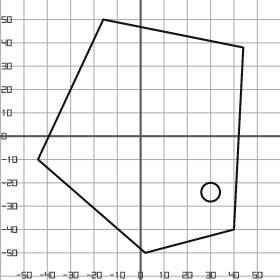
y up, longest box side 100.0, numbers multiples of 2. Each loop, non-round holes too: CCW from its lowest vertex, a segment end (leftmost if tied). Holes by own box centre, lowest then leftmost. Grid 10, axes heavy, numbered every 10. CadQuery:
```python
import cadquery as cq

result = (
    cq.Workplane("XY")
    .moveTo(2.0, -50.0)
    .lineTo(40.0, -40.0)
    .lineTo(44.0, 38.0)
    .lineTo(-16.0, 50.0)
    .lineTo(-44.0, -10.0)
    .close()
    .moveTo(30.0, -24.0)
    .circle(4.0)
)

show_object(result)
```